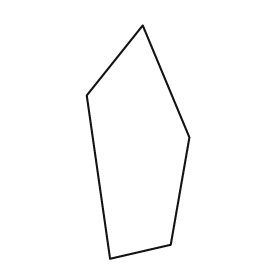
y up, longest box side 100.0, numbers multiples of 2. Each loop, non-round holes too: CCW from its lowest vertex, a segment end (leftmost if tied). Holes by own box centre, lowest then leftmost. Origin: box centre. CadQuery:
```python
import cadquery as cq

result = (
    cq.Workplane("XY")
    .moveTo(-12.0, -50.0)
    .lineTo(14.0, -44.0)
    .lineTo(22.0, 2.0)
    .lineTo(2.0, 50.0)
    .lineTo(-22.0, 20.0)
    .close()
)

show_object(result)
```